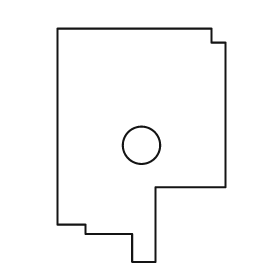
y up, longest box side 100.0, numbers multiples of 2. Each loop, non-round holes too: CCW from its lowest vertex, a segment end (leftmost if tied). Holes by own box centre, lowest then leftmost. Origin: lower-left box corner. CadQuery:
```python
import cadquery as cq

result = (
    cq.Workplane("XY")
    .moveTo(32.0, 0.0)
    .lineTo(42.0, 0.0)
    .lineTo(42.0, 32.0)
    .lineTo(72.0, 32.0)
    .lineTo(72.0, 94.0)
    .lineTo(66.0, 94.0)
    .lineTo(66.0, 100.0)
    .lineTo(0.0, 100.0)
    .lineTo(0.0, 16.0)
    .lineTo(12.0, 16.0)
    .lineTo(12.0, 12.0)
    .lineTo(32.0, 12.0)
    .close()
    .moveTo(36.0, 50.0)
    .circle(8.0)
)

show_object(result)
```